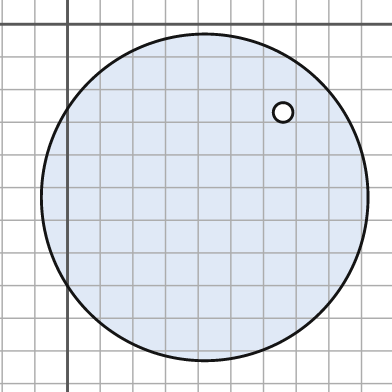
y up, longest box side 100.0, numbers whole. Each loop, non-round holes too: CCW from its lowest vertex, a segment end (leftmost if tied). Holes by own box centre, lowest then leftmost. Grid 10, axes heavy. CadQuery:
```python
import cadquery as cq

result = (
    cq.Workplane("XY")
    .moveTo(42.0, -53.0)
    .circle(50.0)
    .moveTo(66.0, -27.0)
    .circle(3.0)
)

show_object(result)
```